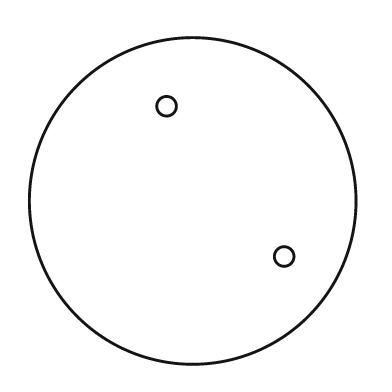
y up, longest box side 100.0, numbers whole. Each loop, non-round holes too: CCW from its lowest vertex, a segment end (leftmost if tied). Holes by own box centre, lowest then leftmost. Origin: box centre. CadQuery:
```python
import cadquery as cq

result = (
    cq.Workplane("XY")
    .moveTo(0.0, 0.0)
    .circle(50.0)
    .moveTo(28.0, -17.0)
    .circle(3.0)
    .moveTo(-8.0, 29.0)
    .circle(3.0)
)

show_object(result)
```